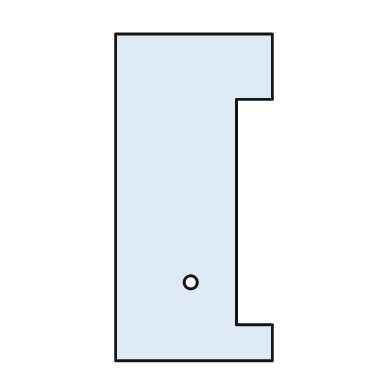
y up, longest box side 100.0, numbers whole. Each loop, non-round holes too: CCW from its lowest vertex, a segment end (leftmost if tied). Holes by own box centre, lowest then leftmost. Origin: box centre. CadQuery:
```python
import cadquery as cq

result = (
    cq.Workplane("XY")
    .moveTo(-24.0, -50.0)
    .lineTo(24.0, -50.0)
    .lineTo(24.0, -39.0)
    .lineTo(13.0, -39.0)
    .lineTo(13.0, 30.0)
    .lineTo(24.0, 30.0)
    .lineTo(24.0, 50.0)
    .lineTo(-24.0, 50.0)
    .close()
    .moveTo(-1.0, -26.0)
    .circle(2.0)
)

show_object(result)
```